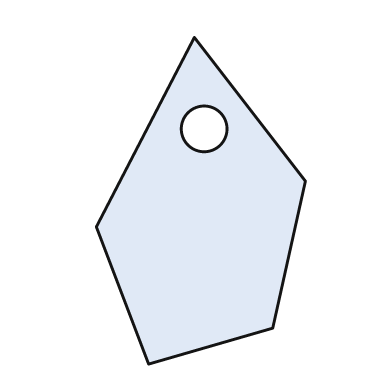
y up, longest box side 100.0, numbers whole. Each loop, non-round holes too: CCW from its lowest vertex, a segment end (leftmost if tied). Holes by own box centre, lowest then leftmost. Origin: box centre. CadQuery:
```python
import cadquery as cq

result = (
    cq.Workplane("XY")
    .moveTo(-16.0, -50.0)
    .lineTo(22.0, -39.0)
    .lineTo(32.0, 6.0)
    .lineTo(-2.0, 50.0)
    .lineTo(-32.0, -8.0)
    .close()
    .moveTo(1.0, 22.0)
    .circle(7.0)
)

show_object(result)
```